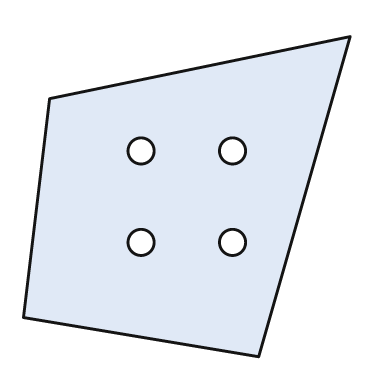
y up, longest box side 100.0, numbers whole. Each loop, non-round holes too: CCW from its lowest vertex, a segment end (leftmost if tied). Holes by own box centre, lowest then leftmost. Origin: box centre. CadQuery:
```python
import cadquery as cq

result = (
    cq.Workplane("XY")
    .moveTo(22.0, -49.0)
    .lineTo(50.0, 49.0)
    .lineTo(-42.0, 30.0)
    .lineTo(-50.0, -37.0)
    .close()
    .moveTo(-14.0, -14.0)
    .circle(4.0)
    .moveTo(14.0, -14.0)
    .circle(4.0)
    .moveTo(-14.0, 14.0)
    .circle(4.0)
    .moveTo(14.0, 14.0)
    .circle(4.0)
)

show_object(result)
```